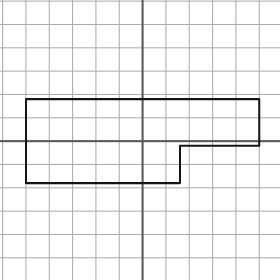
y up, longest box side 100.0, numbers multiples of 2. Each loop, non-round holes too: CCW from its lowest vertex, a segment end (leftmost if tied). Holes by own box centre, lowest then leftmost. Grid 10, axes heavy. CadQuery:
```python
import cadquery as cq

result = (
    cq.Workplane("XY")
    .moveTo(-50.0, -18.0)
    .lineTo(16.0, -18.0)
    .lineTo(16.0, -2.0)
    .lineTo(50.0, -2.0)
    .lineTo(50.0, 18.0)
    .lineTo(-50.0, 18.0)
    .close()
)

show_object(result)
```